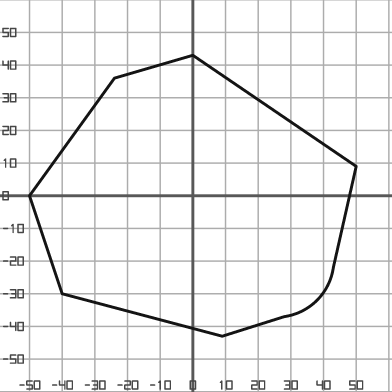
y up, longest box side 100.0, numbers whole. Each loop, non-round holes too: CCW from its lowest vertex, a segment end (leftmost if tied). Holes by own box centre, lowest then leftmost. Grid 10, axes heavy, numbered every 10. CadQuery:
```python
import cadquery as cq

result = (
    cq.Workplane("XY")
    .moveTo(9.0, -43.0)
    .lineTo(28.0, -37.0)
    .threePointArc((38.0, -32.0), (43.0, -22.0))
    .lineTo(50.0, 9.0)
    .lineTo(0.0, 43.0)
    .lineTo(-24.0, 36.0)
    .lineTo(-50.0, 0.0)
    .lineTo(-40.0, -30.0)
    .close()
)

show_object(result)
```